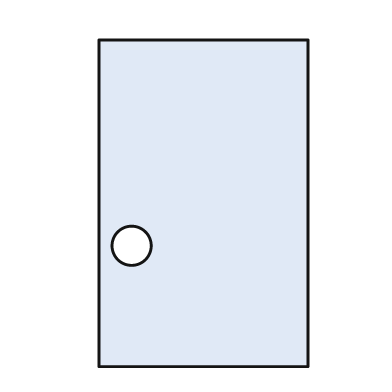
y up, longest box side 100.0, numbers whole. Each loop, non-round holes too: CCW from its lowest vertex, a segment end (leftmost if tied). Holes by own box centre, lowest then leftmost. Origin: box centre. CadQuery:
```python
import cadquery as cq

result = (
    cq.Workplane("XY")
    .moveTo(-32.0, -50.0)
    .lineTo(32.0, -50.0)
    .lineTo(32.0, 50.0)
    .lineTo(-32.0, 50.0)
    .close()
    .moveTo(-22.0, -13.0)
    .circle(6.0)
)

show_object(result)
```